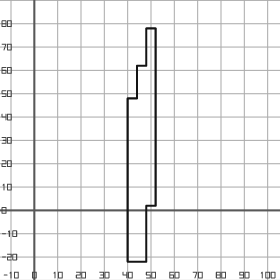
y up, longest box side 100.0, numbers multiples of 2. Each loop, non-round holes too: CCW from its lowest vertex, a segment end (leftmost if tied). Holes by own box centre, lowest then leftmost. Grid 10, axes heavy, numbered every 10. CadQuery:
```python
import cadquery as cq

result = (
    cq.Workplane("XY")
    .moveTo(40.0, -22.0)
    .lineTo(48.0, -22.0)
    .lineTo(48.0, 2.0)
    .lineTo(52.0, 2.0)
    .lineTo(52.0, 78.0)
    .lineTo(48.0, 78.0)
    .lineTo(48.0, 62.0)
    .lineTo(44.0, 62.0)
    .lineTo(44.0, 48.0)
    .lineTo(40.0, 48.0)
    .close()
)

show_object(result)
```